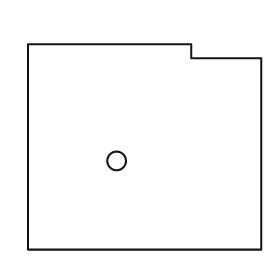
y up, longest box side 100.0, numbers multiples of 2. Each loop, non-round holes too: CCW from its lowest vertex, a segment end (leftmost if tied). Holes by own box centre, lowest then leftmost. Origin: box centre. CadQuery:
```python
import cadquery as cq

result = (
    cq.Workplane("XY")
    .moveTo(-50.0, -44.0)
    .lineTo(50.0, -44.0)
    .lineTo(50.0, 38.0)
    .lineTo(20.0, 38.0)
    .lineTo(20.0, 44.0)
    .lineTo(-50.0, 44.0)
    .close()
    .moveTo(-12.0, -6.0)
    .circle(4.0)
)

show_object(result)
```